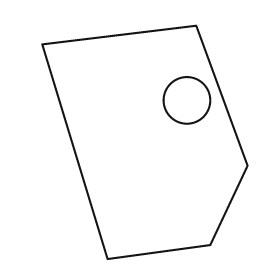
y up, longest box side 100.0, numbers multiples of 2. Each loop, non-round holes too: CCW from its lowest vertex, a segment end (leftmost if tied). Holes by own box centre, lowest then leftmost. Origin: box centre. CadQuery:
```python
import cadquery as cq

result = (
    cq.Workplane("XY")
    .moveTo(-16.0, -50.0)
    .lineTo(28.0, -44.0)
    .lineTo(44.0, -10.0)
    .lineTo(22.0, 50.0)
    .lineTo(-44.0, 42.0)
    .close()
    .moveTo(18.0, 18.0)
    .circle(10.0)
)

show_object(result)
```